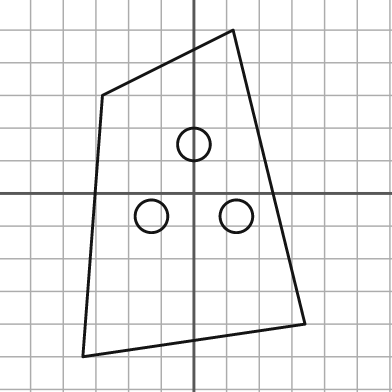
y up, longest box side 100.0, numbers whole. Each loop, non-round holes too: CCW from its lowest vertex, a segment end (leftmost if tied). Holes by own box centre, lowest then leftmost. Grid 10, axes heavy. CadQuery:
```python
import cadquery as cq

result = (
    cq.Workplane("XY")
    .moveTo(-34.0, -50.0)
    .lineTo(34.0, -40.0)
    .lineTo(12.0, 50.0)
    .lineTo(-28.0, 30.0)
    .close()
    .moveTo(-13.0, -7.0)
    .circle(5.0)
    .moveTo(13.0, -7.0)
    .circle(5.0)
    .moveTo(0.0, 15.0)
    .circle(5.0)
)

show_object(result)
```